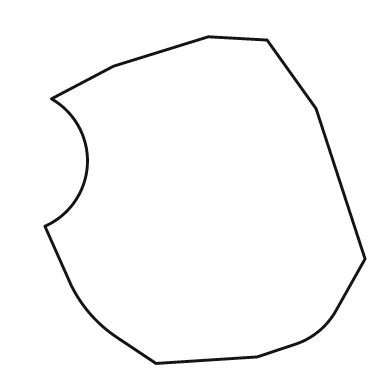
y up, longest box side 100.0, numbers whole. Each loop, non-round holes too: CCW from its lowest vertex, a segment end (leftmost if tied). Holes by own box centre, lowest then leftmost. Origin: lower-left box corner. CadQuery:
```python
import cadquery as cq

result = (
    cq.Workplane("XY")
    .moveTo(34.0, 0.0)
    .lineTo(65.0, 2.0)
    .lineTo(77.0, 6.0)
    .threePointArc((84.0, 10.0), (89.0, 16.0))
    .lineTo(98.0, 32.0)
    .lineTo(83.0, 78.0)
    .lineTo(68.0, 99.0)
    .lineTo(50.0, 100.0)
    .lineTo(21.0, 91.0)
    .lineTo(2.0, 81.0)
    .threePointArc((13.0, 61.0), (0.0, 42.0))
    .lineTo(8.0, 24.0)
    .threePointArc((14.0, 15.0), (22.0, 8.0))
    .close()
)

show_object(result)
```